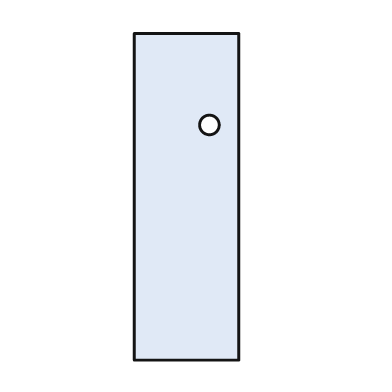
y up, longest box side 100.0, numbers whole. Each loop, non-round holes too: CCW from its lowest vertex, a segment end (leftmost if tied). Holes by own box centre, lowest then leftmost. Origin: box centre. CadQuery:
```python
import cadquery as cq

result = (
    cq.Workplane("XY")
    .moveTo(-16.0, -50.0)
    .lineTo(16.0, -50.0)
    .lineTo(16.0, 50.0)
    .lineTo(-16.0, 50.0)
    .close()
    .moveTo(7.0, 22.0)
    .circle(3.0)
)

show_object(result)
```